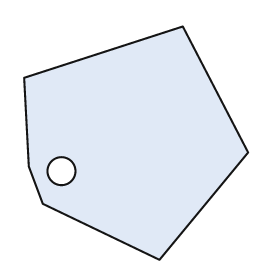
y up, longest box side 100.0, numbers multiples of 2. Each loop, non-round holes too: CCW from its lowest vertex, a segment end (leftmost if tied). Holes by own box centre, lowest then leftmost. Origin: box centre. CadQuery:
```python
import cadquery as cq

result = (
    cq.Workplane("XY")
    .moveTo(10.0, -50.0)
    .lineTo(48.0, -4.0)
    .lineTo(20.0, 50.0)
    .lineTo(-48.0, 28.0)
    .lineTo(-46.0, -10.0)
    .lineTo(-40.0, -26.0)
    .close()
    .moveTo(-32.0, -12.0)
    .circle(6.0)
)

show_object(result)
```